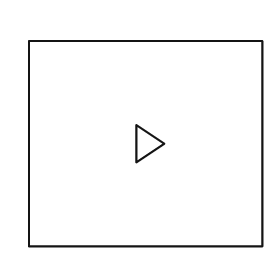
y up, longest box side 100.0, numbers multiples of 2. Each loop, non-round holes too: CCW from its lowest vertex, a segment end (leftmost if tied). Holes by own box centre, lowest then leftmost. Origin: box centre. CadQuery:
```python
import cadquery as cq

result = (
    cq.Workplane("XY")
    .moveTo(-50.0, -44.0)
    .lineTo(50.0, -44.0)
    .lineTo(50.0, 44.0)
    .lineTo(-50.0, 44.0)
    .close()
    .moveTo(-4.0, -8.0)
    .lineTo(8.0, 0.0)
    .lineTo(-4.0, 8.0)
    .close()
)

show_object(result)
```